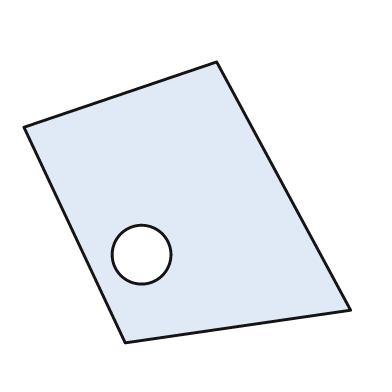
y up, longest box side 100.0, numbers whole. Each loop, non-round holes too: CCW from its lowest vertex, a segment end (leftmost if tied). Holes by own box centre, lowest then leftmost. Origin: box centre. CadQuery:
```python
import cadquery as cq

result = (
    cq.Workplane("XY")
    .moveTo(-19.0, -43.0)
    .lineTo(50.0, -33.0)
    .lineTo(9.0, 43.0)
    .lineTo(-50.0, 23.0)
    .close()
    .moveTo(-14.0, -16.0)
    .circle(9.0)
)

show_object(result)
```